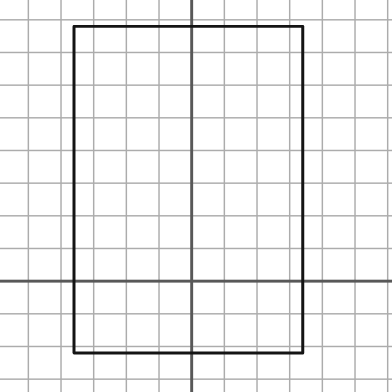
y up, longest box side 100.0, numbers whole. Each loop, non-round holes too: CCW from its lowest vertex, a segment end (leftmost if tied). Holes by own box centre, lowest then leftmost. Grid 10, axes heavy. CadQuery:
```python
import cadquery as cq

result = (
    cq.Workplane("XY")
    .moveTo(-36.0, -22.0)
    .lineTo(34.0, -22.0)
    .lineTo(34.0, 78.0)
    .lineTo(-36.0, 78.0)
    .close()
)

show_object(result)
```